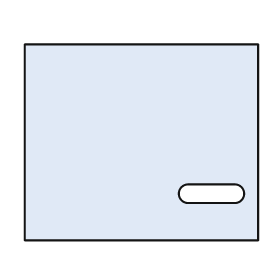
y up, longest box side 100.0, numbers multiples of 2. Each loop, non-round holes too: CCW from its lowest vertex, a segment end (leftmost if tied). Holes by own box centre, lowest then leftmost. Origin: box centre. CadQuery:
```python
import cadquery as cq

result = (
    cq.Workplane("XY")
    .moveTo(-50.0, -42.0)
    .lineTo(50.0, -42.0)
    .lineTo(50.0, 42.0)
    .lineTo(-50.0, 42.0)
    .close()
    .moveTo(20.0, -26.0)
    .lineTo(40.0, -26.0)
    .threePointArc((44.0, -22.0), (40.0, -18.0))
    .lineTo(20.0, -18.0)
    .threePointArc((16.0, -22.0), (20.0, -26.0))
    .close()
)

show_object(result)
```